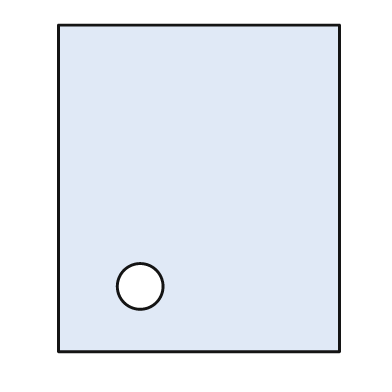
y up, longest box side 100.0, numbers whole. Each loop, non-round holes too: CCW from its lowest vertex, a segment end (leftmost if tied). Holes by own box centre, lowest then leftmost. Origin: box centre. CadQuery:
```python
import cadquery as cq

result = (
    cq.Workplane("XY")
    .moveTo(-43.0, -50.0)
    .lineTo(43.0, -50.0)
    .lineTo(43.0, 50.0)
    .lineTo(-43.0, 50.0)
    .close()
    .moveTo(-18.0, -30.0)
    .circle(7.0)
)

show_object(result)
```